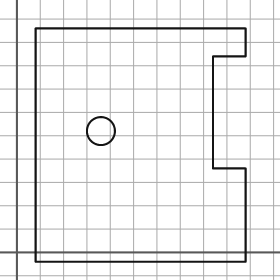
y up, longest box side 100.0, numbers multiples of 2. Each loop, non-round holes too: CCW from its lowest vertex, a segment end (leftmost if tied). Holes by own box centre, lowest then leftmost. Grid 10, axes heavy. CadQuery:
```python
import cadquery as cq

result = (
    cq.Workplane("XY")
    .moveTo(8.0, -4.0)
    .lineTo(98.0, -4.0)
    .lineTo(98.0, 36.0)
    .lineTo(84.0, 36.0)
    .lineTo(84.0, 84.0)
    .lineTo(98.0, 84.0)
    .lineTo(98.0, 96.0)
    .lineTo(8.0, 96.0)
    .close()
    .moveTo(36.0, 52.0)
    .circle(6.0)
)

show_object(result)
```